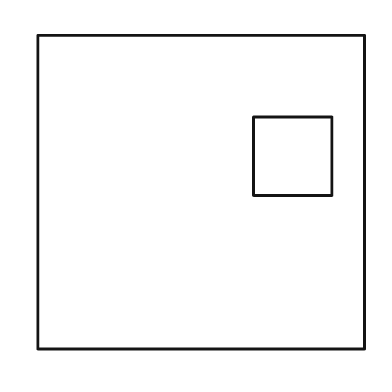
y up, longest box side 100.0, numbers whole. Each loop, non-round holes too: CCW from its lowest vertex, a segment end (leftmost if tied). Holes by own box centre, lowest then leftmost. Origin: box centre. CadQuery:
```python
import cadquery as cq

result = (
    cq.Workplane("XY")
    .moveTo(-50.0, -48.0)
    .lineTo(50.0, -48.0)
    .lineTo(50.0, 48.0)
    .lineTo(-50.0, 48.0)
    .close()
    .moveTo(16.0, -1.0)
    .lineTo(40.0, -1.0)
    .lineTo(40.0, 23.0)
    .lineTo(16.0, 23.0)
    .close()
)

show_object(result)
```